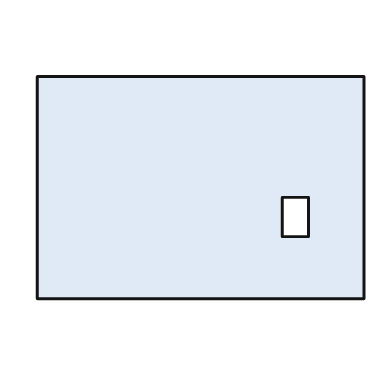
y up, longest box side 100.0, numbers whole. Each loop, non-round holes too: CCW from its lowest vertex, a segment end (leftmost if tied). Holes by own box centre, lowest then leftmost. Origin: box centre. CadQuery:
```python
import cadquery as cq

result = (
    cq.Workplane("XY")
    .moveTo(-50.0, -34.0)
    .lineTo(50.0, -34.0)
    .lineTo(50.0, 34.0)
    .lineTo(-50.0, 34.0)
    .close()
    .moveTo(25.0, -15.0)
    .lineTo(33.0, -15.0)
    .lineTo(33.0, -3.0)
    .lineTo(25.0, -3.0)
    .close()
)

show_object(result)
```